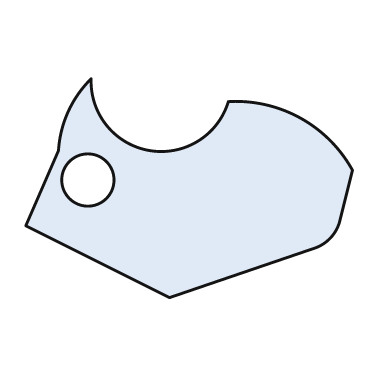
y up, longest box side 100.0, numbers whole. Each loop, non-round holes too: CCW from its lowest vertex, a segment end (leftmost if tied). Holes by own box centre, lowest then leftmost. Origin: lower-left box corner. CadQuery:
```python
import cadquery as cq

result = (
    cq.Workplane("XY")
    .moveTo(44.0, 0.0)
    .lineTo(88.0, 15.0)
    .threePointArc((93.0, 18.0), (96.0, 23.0))
    .lineTo(100.0, 39.0)
    .threePointArc((84.0, 55.0), (62.0, 60.0))
    .threePointArc((38.0, 45.0), (20.0, 67.0))
    .threePointArc((13.0, 57.0), (10.0, 45.0))
    .lineTo(0.0, 22.0)
    .close()
    .moveTo(19.0, 36.0)
    .circle(8.0)
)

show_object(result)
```